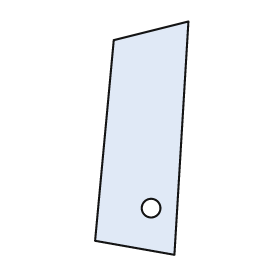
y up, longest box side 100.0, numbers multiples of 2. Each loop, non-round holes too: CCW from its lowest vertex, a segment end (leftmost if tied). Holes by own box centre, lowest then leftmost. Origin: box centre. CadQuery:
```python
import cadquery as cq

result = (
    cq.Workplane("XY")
    .moveTo(14.0, -50.0)
    .lineTo(20.0, 50.0)
    .lineTo(-12.0, 42.0)
    .lineTo(-20.0, -44.0)
    .close()
    .moveTo(4.0, -30.0)
    .circle(4.0)
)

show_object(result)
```